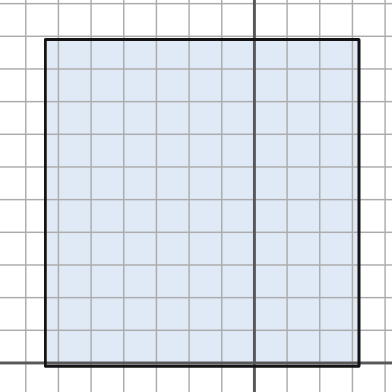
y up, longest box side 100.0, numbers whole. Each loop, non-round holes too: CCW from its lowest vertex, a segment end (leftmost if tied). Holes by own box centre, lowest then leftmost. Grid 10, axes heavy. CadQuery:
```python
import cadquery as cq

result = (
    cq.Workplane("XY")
    .moveTo(-64.0, -1.0)
    .lineTo(32.0, -1.0)
    .lineTo(32.0, 99.0)
    .lineTo(-64.0, 99.0)
    .close()
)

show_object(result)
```